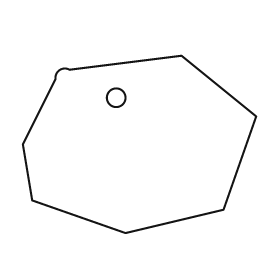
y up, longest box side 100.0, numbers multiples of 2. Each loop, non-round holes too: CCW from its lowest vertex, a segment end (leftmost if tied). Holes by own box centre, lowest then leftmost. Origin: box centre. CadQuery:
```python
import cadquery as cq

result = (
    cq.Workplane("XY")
    .moveTo(-6.0, -38.0)
    .lineTo(36.0, -28.0)
    .lineTo(50.0, 12.0)
    .lineTo(18.0, 38.0)
    .lineTo(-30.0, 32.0)
    .threePointArc((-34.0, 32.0), (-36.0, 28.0))
    .lineTo(-50.0, 0.0)
    .lineTo(-46.0, -24.0)
    .close()
    .moveTo(-10.0, 20.0)
    .circle(4.0)
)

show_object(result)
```